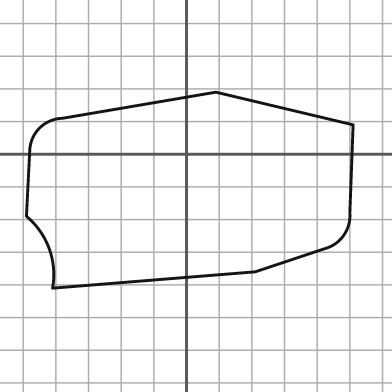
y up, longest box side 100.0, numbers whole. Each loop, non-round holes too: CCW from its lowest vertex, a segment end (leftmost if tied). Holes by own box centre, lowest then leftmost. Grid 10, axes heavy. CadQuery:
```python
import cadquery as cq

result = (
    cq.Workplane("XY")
    .moveTo(-41.0, -41.0)
    .lineTo(21.0, -36.0)
    .lineTo(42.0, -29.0)
    .threePointArc((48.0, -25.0), (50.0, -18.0))
    .lineTo(51.0, 9.0)
    .lineTo(9.0, 19.0)
    .lineTo(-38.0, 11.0)
    .threePointArc((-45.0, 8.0), (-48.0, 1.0))
    .lineTo(-49.0, -19.0)
    .threePointArc((-42.0, -29.0), (-41.0, -41.0))
    .close()
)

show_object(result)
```